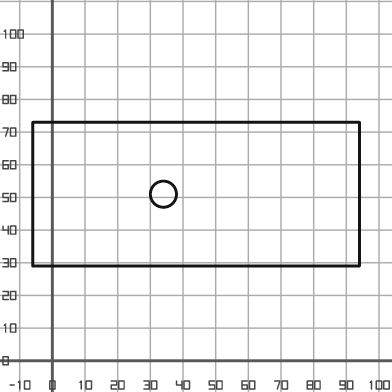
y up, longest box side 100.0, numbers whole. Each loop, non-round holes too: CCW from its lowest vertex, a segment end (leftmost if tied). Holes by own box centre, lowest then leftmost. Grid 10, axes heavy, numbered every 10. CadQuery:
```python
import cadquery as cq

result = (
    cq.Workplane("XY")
    .moveTo(-6.0, 29.0)
    .lineTo(94.0, 29.0)
    .lineTo(94.0, 73.0)
    .lineTo(-6.0, 73.0)
    .close()
    .moveTo(34.0, 51.0)
    .circle(4.0)
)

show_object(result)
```